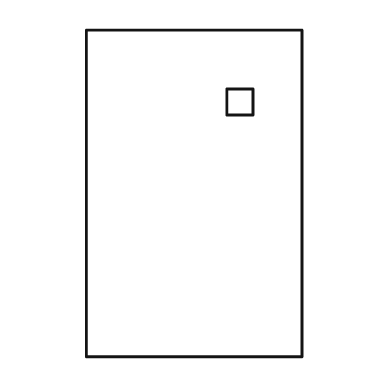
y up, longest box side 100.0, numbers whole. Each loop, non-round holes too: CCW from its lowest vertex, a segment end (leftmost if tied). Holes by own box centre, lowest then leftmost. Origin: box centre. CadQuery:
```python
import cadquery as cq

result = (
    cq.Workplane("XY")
    .moveTo(-33.0, -50.0)
    .lineTo(33.0, -50.0)
    .lineTo(33.0, 50.0)
    .lineTo(-33.0, 50.0)
    .close()
    .moveTo(10.0, 24.0)
    .lineTo(18.0, 24.0)
    .lineTo(18.0, 32.0)
    .lineTo(10.0, 32.0)
    .close()
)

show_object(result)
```